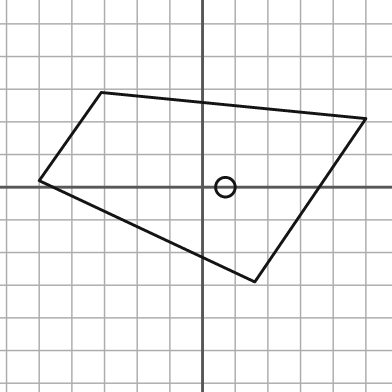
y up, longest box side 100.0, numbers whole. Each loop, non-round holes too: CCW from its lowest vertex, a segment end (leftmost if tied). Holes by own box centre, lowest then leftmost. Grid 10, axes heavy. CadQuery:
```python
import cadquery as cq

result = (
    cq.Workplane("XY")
    .moveTo(16.0, -29.0)
    .lineTo(50.0, 21.0)
    .lineTo(-31.0, 29.0)
    .lineTo(-50.0, 2.0)
    .close()
    .moveTo(7.0, 0.0)
    .circle(3.0)
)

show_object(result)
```